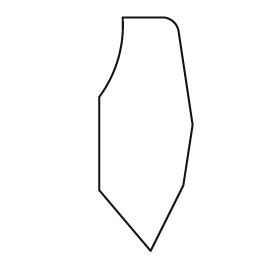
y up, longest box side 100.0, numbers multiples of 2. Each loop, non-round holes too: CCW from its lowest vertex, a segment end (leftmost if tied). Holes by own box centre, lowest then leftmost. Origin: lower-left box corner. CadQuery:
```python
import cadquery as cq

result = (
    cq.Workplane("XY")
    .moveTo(22.0, 0.0)
    .lineTo(36.0, 28.0)
    .lineTo(40.0, 54.0)
    .lineTo(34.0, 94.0)
    .threePointArc((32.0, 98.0), (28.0, 100.0))
    .lineTo(10.0, 100.0)
    .threePointArc((8.0, 82.0), (0.0, 66.0))
    .lineTo(0.0, 26.0)
    .close()
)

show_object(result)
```